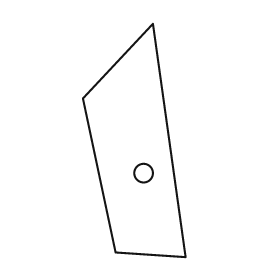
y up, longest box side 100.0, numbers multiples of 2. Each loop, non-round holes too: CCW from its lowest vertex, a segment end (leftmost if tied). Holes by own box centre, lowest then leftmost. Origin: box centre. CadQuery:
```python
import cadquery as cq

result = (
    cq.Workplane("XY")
    .moveTo(22.0, -50.0)
    .lineTo(8.0, 50.0)
    .lineTo(-22.0, 18.0)
    .lineTo(-8.0, -48.0)
    .close()
    .moveTo(4.0, -14.0)
    .circle(4.0)
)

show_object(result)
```